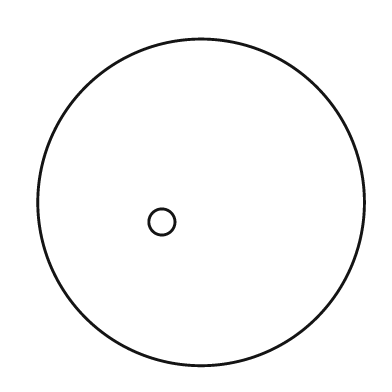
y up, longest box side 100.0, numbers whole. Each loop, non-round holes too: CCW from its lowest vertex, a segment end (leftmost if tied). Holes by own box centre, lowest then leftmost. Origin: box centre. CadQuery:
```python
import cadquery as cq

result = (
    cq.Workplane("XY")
    .moveTo(0.0, 0.0)
    .circle(50.0)
    .moveTo(-12.0, -6.0)
    .circle(4.0)
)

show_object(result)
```